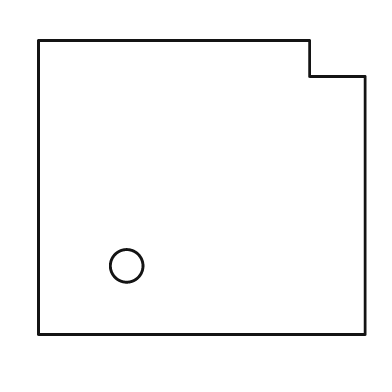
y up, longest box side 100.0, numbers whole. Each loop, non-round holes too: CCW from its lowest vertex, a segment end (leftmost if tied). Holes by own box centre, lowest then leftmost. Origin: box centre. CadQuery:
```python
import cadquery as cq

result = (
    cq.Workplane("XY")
    .moveTo(-50.0, -45.0)
    .lineTo(50.0, -45.0)
    .lineTo(50.0, 34.0)
    .lineTo(33.0, 34.0)
    .lineTo(33.0, 45.0)
    .lineTo(-50.0, 45.0)
    .close()
    .moveTo(-23.0, -24.0)
    .circle(5.0)
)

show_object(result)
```